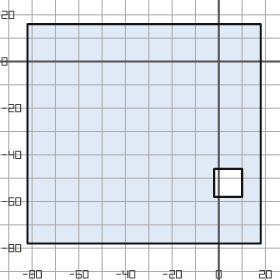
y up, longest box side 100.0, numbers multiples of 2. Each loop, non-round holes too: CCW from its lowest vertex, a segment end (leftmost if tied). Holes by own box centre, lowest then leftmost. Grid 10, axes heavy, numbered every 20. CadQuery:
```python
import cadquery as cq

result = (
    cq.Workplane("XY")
    .moveTo(-82.0, -78.0)
    .lineTo(18.0, -78.0)
    .lineTo(18.0, 16.0)
    .lineTo(-82.0, 16.0)
    .close()
    .moveTo(-2.0, -58.0)
    .lineTo(10.0, -58.0)
    .lineTo(10.0, -46.0)
    .lineTo(-2.0, -46.0)
    .close()
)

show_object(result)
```